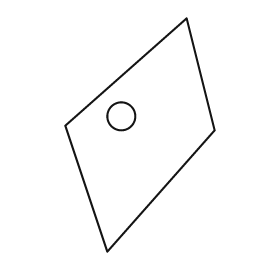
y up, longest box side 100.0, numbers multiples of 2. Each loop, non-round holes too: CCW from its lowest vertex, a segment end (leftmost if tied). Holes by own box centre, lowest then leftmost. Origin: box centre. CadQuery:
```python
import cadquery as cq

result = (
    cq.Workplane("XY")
    .moveTo(-14.0, -50.0)
    .lineTo(32.0, 2.0)
    .lineTo(20.0, 50.0)
    .lineTo(-32.0, 4.0)
    .close()
    .moveTo(-8.0, 8.0)
    .circle(6.0)
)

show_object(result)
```